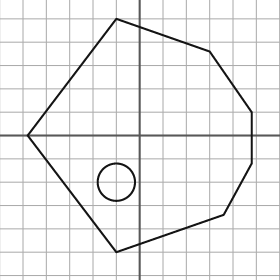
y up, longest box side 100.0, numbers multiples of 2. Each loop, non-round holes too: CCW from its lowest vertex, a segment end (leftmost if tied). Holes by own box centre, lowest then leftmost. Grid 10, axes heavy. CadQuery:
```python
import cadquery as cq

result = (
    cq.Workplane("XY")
    .moveTo(-10.0, -50.0)
    .lineTo(36.0, -34.0)
    .lineTo(48.0, -12.0)
    .lineTo(48.0, 10.0)
    .lineTo(30.0, 36.0)
    .lineTo(-10.0, 50.0)
    .lineTo(-48.0, 0.0)
    .close()
    .moveTo(-10.0, -20.0)
    .circle(8.0)
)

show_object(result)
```